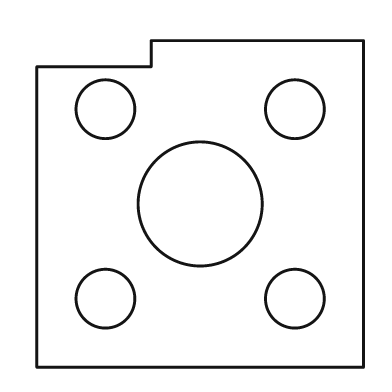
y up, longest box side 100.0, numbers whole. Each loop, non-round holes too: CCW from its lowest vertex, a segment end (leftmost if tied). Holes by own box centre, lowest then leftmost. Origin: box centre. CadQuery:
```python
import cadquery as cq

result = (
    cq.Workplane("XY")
    .moveTo(-50.0, -50.0)
    .lineTo(50.0, -50.0)
    .lineTo(50.0, 50.0)
    .lineTo(-15.0, 50.0)
    .lineTo(-15.0, 42.0)
    .lineTo(-50.0, 42.0)
    .close()
    .moveTo(-29.0, -29.0)
    .circle(9.0)
    .moveTo(29.0, -29.0)
    .circle(9.0)
    .moveTo(0.0, 0.0)
    .circle(19.0)
    .moveTo(-29.0, 29.0)
    .circle(9.0)
    .moveTo(29.0, 29.0)
    .circle(9.0)
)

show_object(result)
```